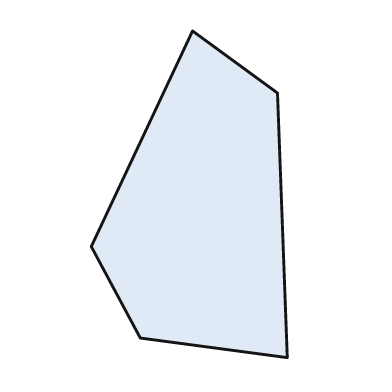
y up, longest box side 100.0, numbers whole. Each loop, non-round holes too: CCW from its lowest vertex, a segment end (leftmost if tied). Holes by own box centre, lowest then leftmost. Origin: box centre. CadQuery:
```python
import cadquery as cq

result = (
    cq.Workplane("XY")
    .moveTo(30.0, -50.0)
    .lineTo(27.0, 31.0)
    .lineTo(1.0, 50.0)
    .lineTo(-30.0, -16.0)
    .lineTo(-15.0, -44.0)
    .close()
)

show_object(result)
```